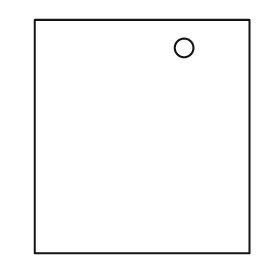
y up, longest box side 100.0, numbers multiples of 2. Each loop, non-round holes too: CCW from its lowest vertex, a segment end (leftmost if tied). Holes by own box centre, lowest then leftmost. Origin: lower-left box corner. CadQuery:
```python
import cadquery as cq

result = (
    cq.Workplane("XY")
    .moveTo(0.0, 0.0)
    .lineTo(92.0, 0.0)
    .lineTo(92.0, 100.0)
    .lineTo(0.0, 100.0)
    .close()
    .moveTo(64.0, 88.0)
    .circle(4.0)
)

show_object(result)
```